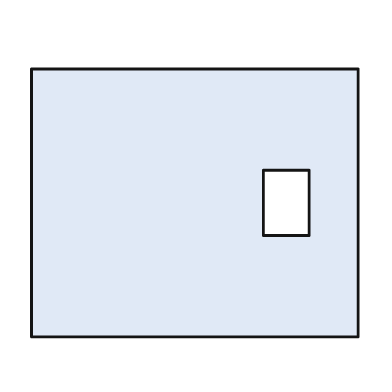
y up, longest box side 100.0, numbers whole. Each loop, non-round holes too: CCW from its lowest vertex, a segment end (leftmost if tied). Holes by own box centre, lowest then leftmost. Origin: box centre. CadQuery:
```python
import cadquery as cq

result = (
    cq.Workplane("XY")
    .moveTo(-50.0, -41.0)
    .lineTo(50.0, -41.0)
    .lineTo(50.0, 41.0)
    .lineTo(-50.0, 41.0)
    .close()
    .moveTo(21.0, -10.0)
    .lineTo(35.0, -10.0)
    .lineTo(35.0, 10.0)
    .lineTo(21.0, 10.0)
    .close()
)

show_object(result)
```